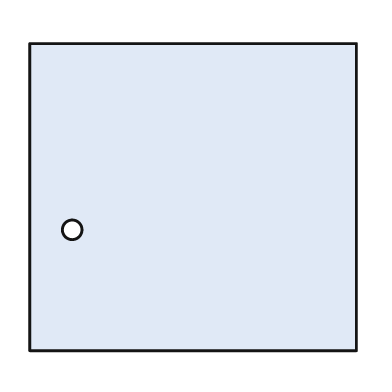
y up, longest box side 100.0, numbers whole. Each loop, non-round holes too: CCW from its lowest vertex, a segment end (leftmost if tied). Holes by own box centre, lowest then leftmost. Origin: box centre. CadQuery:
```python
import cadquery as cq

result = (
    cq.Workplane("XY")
    .moveTo(-50.0, -47.0)
    .lineTo(50.0, -47.0)
    .lineTo(50.0, 47.0)
    .lineTo(-50.0, 47.0)
    .close()
    .moveTo(-37.0, -10.0)
    .circle(3.0)
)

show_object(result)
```